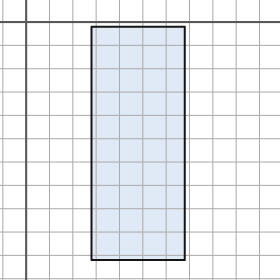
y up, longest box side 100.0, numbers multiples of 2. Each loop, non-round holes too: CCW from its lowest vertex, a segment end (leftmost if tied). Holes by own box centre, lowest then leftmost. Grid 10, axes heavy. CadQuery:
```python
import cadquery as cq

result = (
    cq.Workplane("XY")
    .moveTo(28.0, -102.0)
    .lineTo(68.0, -102.0)
    .lineTo(68.0, -2.0)
    .lineTo(28.0, -2.0)
    .close()
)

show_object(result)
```